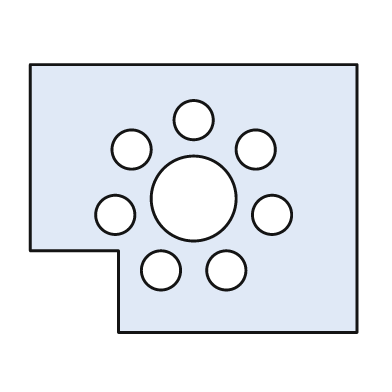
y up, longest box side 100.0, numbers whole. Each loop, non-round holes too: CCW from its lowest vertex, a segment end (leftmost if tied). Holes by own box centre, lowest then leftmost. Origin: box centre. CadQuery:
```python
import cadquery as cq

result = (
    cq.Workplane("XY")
    .moveTo(-23.0, -41.0)
    .lineTo(50.0, -41.0)
    .lineTo(50.0, 41.0)
    .lineTo(-50.0, 41.0)
    .lineTo(-50.0, -16.0)
    .lineTo(-23.0, -16.0)
    .close()
    .moveTo(-10.0, -22.0)
    .circle(6.0)
    .moveTo(10.0, -22.0)
    .circle(6.0)
    .moveTo(-24.0, -5.0)
    .circle(6.0)
    .moveTo(24.0, -5.0)
    .circle(6.0)
    .moveTo(0.0, 0.0)
    .circle(13.0)
    .moveTo(-19.0, 15.0)
    .circle(6.0)
    .moveTo(19.0, 15.0)
    .circle(6.0)
    .moveTo(0.0, 24.0)
    .circle(6.0)
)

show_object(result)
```